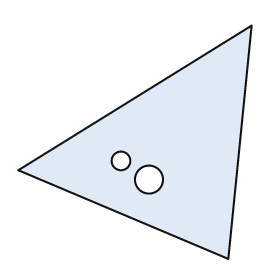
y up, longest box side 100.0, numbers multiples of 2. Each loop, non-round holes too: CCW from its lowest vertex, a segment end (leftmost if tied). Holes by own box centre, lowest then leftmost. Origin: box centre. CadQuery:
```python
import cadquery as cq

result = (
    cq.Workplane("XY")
    .moveTo(40.0, -50.0)
    .lineTo(50.0, 50.0)
    .lineTo(-50.0, -12.0)
    .close()
    .moveTo(6.0, -16.0)
    .circle(6.0)
    .moveTo(-6.0, -8.0)
    .circle(4.0)
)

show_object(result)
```